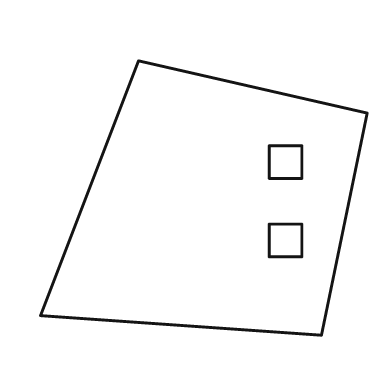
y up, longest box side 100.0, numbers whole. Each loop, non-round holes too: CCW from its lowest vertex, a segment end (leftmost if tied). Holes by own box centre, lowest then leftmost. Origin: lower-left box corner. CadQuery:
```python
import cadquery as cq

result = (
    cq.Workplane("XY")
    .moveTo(86.0, 0.0)
    .lineTo(100.0, 68.0)
    .lineTo(30.0, 84.0)
    .lineTo(0.0, 6.0)
    .close()
    .moveTo(70.0, 24.0)
    .lineTo(80.0, 24.0)
    .lineTo(80.0, 34.0)
    .lineTo(70.0, 34.0)
    .close()
    .moveTo(70.0, 48.0)
    .lineTo(80.0, 48.0)
    .lineTo(80.0, 58.0)
    .lineTo(70.0, 58.0)
    .close()
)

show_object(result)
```